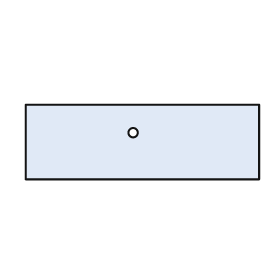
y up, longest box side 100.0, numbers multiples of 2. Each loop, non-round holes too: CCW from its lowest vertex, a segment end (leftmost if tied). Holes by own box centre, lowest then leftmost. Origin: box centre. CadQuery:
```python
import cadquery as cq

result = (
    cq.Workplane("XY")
    .moveTo(-50.0, -16.0)
    .lineTo(50.0, -16.0)
    .lineTo(50.0, 16.0)
    .lineTo(-50.0, 16.0)
    .close()
    .moveTo(-4.0, 4.0)
    .circle(2.0)
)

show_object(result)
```